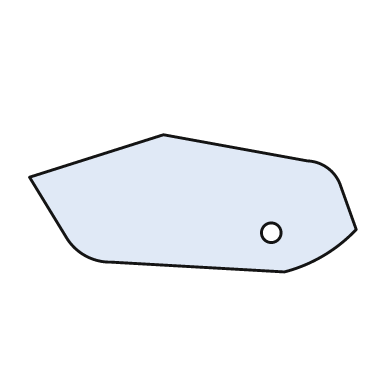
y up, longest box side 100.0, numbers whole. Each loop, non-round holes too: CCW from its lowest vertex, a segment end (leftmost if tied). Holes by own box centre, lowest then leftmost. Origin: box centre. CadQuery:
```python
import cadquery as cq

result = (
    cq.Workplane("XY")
    .moveTo(28.0, -21.0)
    .threePointArc((40.0, -16.0), (50.0, -8.0))
    .lineTo(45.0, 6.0)
    .threePointArc((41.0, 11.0), (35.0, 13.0))
    .lineTo(-9.0, 21.0)
    .lineTo(-50.0, 8.0)
    .lineTo(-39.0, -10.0)
    .threePointArc((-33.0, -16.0), (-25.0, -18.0))
    .close()
    .moveTo(24.0, -9.0)
    .circle(3.0)
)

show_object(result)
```